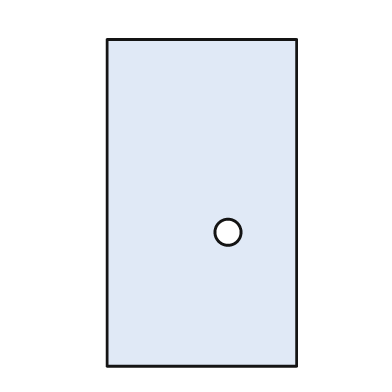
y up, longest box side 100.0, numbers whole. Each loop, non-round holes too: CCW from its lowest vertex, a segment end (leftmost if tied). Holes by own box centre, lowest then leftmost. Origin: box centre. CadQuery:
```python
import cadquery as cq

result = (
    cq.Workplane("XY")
    .moveTo(-29.0, -50.0)
    .lineTo(29.0, -50.0)
    .lineTo(29.0, 50.0)
    .lineTo(-29.0, 50.0)
    .close()
    .moveTo(8.0, -9.0)
    .circle(4.0)
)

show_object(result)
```